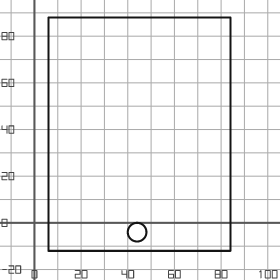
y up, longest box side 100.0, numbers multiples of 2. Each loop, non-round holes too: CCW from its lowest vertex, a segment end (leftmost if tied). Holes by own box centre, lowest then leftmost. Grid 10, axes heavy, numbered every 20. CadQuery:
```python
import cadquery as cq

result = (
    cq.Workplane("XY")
    .moveTo(6.0, -12.0)
    .lineTo(84.0, -12.0)
    .lineTo(84.0, 88.0)
    .lineTo(6.0, 88.0)
    .close()
    .moveTo(44.0, -4.0)
    .circle(4.0)
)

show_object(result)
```